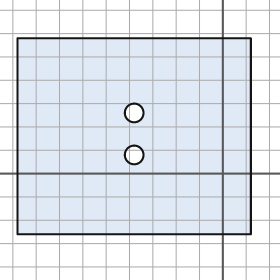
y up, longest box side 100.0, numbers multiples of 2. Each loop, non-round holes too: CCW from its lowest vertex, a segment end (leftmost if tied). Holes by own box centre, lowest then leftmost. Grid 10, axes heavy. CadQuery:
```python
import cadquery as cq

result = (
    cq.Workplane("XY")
    .moveTo(-88.0, -26.0)
    .lineTo(12.0, -26.0)
    .lineTo(12.0, 58.0)
    .lineTo(-88.0, 58.0)
    .close()
    .moveTo(-38.0, 8.0)
    .circle(4.0)
    .moveTo(-38.0, 26.0)
    .circle(4.0)
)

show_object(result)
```